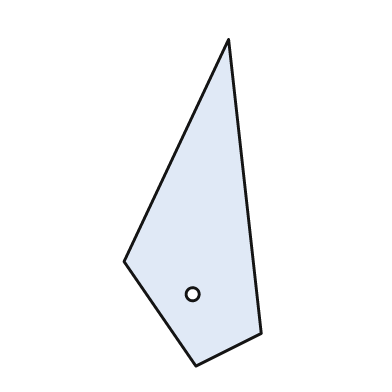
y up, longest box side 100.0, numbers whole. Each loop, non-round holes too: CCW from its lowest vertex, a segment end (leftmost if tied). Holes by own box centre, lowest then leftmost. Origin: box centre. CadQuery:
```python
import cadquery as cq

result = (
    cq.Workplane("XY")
    .moveTo(1.0, -50.0)
    .lineTo(21.0, -40.0)
    .lineTo(11.0, 50.0)
    .lineTo(-21.0, -18.0)
    .close()
    .moveTo(0.0, -28.0)
    .circle(2.0)
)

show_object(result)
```